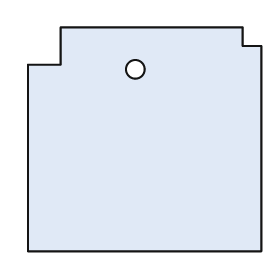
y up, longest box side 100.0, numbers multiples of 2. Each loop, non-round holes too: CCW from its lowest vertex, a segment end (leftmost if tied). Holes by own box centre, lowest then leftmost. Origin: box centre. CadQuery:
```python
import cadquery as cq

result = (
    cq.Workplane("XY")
    .moveTo(-50.0, -48.0)
    .lineTo(50.0, -48.0)
    .lineTo(50.0, 40.0)
    .lineTo(42.0, 40.0)
    .lineTo(42.0, 48.0)
    .lineTo(-36.0, 48.0)
    .lineTo(-36.0, 32.0)
    .lineTo(-50.0, 32.0)
    .close()
    .moveTo(-4.0, 30.0)
    .circle(4.0)
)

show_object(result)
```